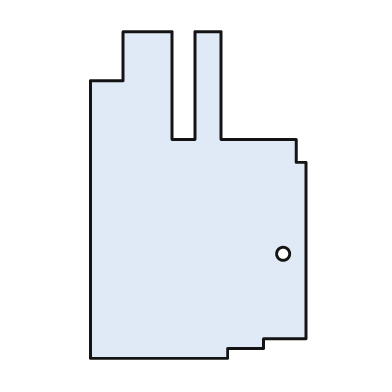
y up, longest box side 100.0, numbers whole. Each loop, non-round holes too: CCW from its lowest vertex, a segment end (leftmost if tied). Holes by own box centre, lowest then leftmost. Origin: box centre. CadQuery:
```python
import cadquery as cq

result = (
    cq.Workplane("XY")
    .moveTo(-33.0, -50.0)
    .lineTo(9.0, -50.0)
    .lineTo(9.0, -47.0)
    .lineTo(20.0, -47.0)
    .lineTo(20.0, -44.0)
    .lineTo(33.0, -44.0)
    .lineTo(33.0, 10.0)
    .lineTo(30.0, 10.0)
    .lineTo(30.0, 17.0)
    .lineTo(7.0, 17.0)
    .lineTo(7.0, 50.0)
    .lineTo(-1.0, 50.0)
    .lineTo(-1.0, 17.0)
    .lineTo(-8.0, 17.0)
    .lineTo(-8.0, 50.0)
    .lineTo(-23.0, 50.0)
    .lineTo(-23.0, 35.0)
    .lineTo(-33.0, 35.0)
    .close()
    .moveTo(26.0, -18.0)
    .circle(2.0)
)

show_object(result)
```